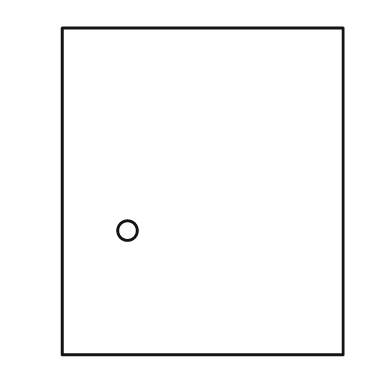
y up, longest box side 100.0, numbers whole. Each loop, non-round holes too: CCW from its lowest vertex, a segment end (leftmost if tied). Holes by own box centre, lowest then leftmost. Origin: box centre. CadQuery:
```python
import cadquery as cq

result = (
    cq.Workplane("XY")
    .moveTo(-43.0, -50.0)
    .lineTo(43.0, -50.0)
    .lineTo(43.0, 50.0)
    .lineTo(-43.0, 50.0)
    .close()
    .moveTo(-23.0, -12.0)
    .circle(3.0)
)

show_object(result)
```